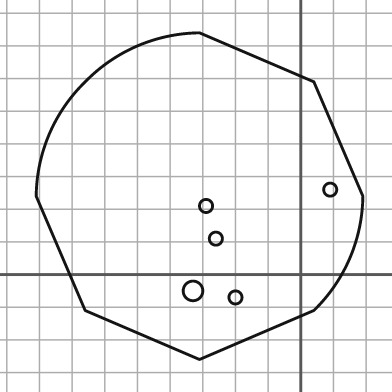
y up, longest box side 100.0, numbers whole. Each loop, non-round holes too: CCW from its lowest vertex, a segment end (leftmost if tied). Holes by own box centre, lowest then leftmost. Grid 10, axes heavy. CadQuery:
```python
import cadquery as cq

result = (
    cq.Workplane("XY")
    .moveTo(-31.0, -26.0)
    .lineTo(4.0, -11.0)
    .threePointArc((15.0, 5.0), (19.0, 24.0))
    .lineTo(4.0, 59.0)
    .lineTo(-31.0, 74.0)
    .threePointArc((-50.0, 70.0), (-66.0, 59.0))
    .threePointArc((-77.0, 43.0), (-81.0, 24.0))
    .lineTo(-66.0, -11.0)
    .close()
    .moveTo(-20.0, -7.0)
    .circle(2.0)
    .moveTo(-33.0, -5.0)
    .circle(3.0)
    .moveTo(-26.0, 11.0)
    .circle(2.0)
    .moveTo(-29.0, 21.0)
    .circle(2.0)
    .moveTo(9.0, 26.0)
    .circle(2.0)
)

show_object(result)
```